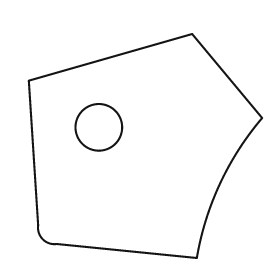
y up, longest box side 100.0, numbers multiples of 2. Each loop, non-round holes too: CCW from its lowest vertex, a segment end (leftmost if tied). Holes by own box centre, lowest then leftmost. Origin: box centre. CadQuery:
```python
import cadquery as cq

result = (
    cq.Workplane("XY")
    .moveTo(22.0, -48.0)
    .threePointArc((32.0, -16.0), (50.0, 12.0))
    .lineTo(20.0, 48.0)
    .lineTo(-50.0, 28.0)
    .lineTo(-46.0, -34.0)
    .threePointArc((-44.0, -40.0), (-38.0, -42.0))
    .close()
    .moveTo(-20.0, 8.0)
    .circle(10.0)
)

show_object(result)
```